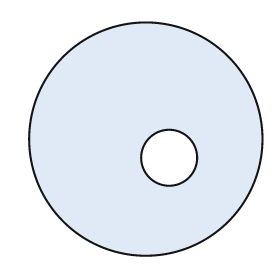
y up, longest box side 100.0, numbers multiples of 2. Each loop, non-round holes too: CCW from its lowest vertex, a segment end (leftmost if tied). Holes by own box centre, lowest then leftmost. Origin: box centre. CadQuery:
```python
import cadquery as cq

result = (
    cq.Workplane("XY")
    .moveTo(0.0, 0.0)
    .circle(50.0)
    .moveTo(10.0, -8.0)
    .circle(12.0)
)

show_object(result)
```